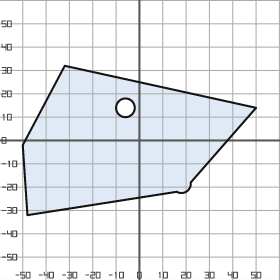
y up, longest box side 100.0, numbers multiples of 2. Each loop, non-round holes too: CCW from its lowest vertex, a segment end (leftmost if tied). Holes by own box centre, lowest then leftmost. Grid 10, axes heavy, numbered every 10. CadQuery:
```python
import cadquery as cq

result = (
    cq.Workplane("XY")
    .moveTo(-48.0, -32.0)
    .lineTo(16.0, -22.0)
    .threePointArc((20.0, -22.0), (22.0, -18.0))
    .lineTo(50.0, 14.0)
    .lineTo(-32.0, 32.0)
    .lineTo(-50.0, -2.0)
    .close()
    .moveTo(-6.0, 14.0)
    .circle(4.0)
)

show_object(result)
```